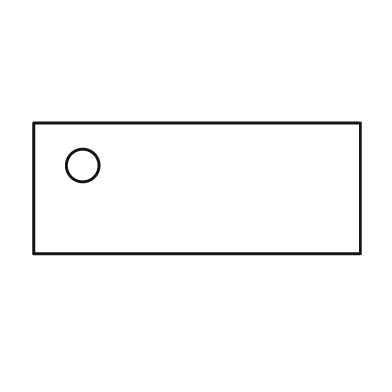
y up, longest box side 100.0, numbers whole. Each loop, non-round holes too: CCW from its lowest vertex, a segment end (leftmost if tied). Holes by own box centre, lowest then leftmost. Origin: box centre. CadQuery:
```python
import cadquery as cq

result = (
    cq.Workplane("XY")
    .moveTo(-50.0, -20.0)
    .lineTo(50.0, -20.0)
    .lineTo(50.0, 20.0)
    .lineTo(-50.0, 20.0)
    .close()
    .moveTo(-35.0, 7.0)
    .circle(5.0)
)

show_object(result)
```